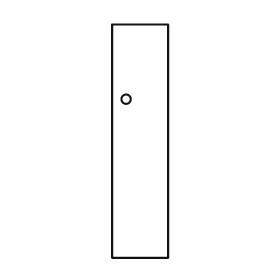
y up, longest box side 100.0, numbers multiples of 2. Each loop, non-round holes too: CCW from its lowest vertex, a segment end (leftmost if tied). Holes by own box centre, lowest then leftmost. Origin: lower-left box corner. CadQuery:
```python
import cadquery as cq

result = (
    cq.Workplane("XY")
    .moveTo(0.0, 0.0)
    .lineTo(24.0, 0.0)
    .lineTo(24.0, 100.0)
    .lineTo(0.0, 100.0)
    .close()
    .moveTo(6.0, 68.0)
    .circle(2.0)
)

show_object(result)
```